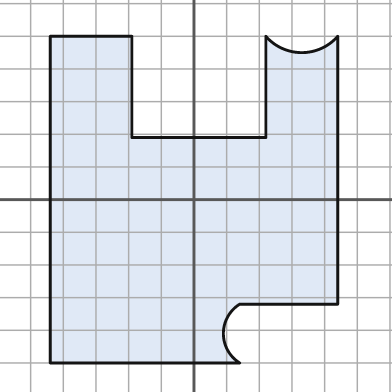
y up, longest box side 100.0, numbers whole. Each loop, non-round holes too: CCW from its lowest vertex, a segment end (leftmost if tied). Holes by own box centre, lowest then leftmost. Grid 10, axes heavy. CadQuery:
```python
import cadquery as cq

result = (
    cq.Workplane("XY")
    .moveTo(-44.0, -50.0)
    .lineTo(14.0, -50.0)
    .threePointArc((9.0, -41.0), (14.0, -32.0))
    .lineTo(44.0, -32.0)
    .lineTo(44.0, 50.0)
    .threePointArc((33.0, 45.0), (22.0, 50.0))
    .lineTo(22.0, 19.0)
    .lineTo(-19.0, 19.0)
    .lineTo(-19.0, 50.0)
    .lineTo(-44.0, 50.0)
    .close()
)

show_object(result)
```